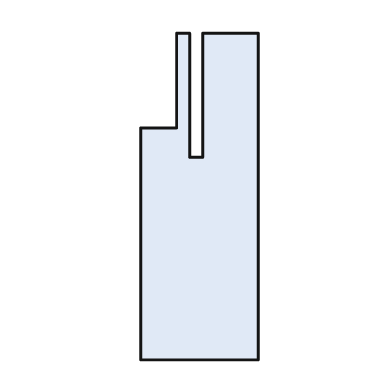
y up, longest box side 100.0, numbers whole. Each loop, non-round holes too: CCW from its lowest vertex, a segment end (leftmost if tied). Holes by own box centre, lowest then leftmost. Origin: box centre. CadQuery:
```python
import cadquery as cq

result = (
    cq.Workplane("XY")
    .moveTo(-18.0, -50.0)
    .lineTo(18.0, -50.0)
    .lineTo(18.0, 50.0)
    .lineTo(1.0, 50.0)
    .lineTo(1.0, 12.0)
    .lineTo(-3.0, 12.0)
    .lineTo(-3.0, 50.0)
    .lineTo(-7.0, 50.0)
    .lineTo(-7.0, 21.0)
    .lineTo(-18.0, 21.0)
    .close()
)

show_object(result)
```